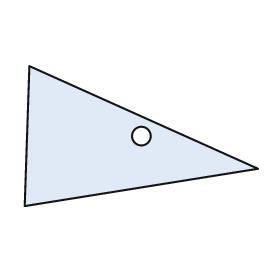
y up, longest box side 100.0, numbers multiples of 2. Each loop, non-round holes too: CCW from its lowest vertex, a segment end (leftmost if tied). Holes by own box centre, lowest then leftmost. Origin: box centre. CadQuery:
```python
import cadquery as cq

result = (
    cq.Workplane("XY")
    .moveTo(-50.0, -30.0)
    .lineTo(50.0, -14.0)
    .lineTo(-48.0, 30.0)
    .close()
    .moveTo(0.0, 0.0)
    .circle(4.0)
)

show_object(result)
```